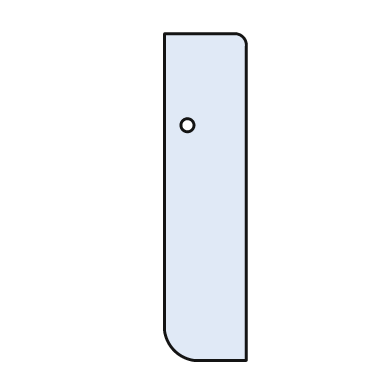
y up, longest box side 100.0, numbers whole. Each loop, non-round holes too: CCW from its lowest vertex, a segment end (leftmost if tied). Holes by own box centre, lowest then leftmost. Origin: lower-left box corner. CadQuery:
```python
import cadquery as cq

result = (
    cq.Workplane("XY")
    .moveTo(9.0, 0.0)
    .lineTo(25.0, 0.0)
    .lineTo(25.0, 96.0)
    .threePointArc((24.0, 99.0), (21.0, 100.0))
    .lineTo(0.0, 100.0)
    .lineTo(0.0, 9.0)
    .threePointArc((3.0, 3.0), (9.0, 0.0))
    .close()
    .moveTo(7.0, 72.0)
    .circle(2.0)
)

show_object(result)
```